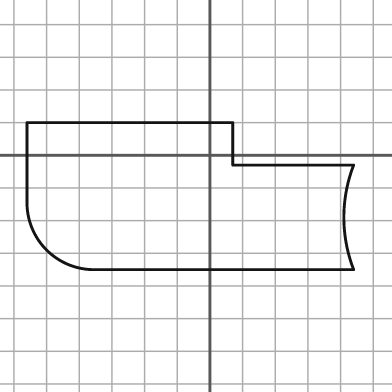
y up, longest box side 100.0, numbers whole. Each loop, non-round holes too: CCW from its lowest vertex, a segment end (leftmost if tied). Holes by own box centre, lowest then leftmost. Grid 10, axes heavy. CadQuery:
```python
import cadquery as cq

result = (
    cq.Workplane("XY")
    .moveTo(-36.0, -35.0)
    .lineTo(44.0, -35.0)
    .threePointArc((41.0, -19.0), (44.0, -3.0))
    .lineTo(7.0, -3.0)
    .lineTo(7.0, 10.0)
    .lineTo(-56.0, 10.0)
    .lineTo(-56.0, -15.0)
    .threePointArc((-50.0, -29.0), (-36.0, -35.0))
    .close()
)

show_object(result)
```